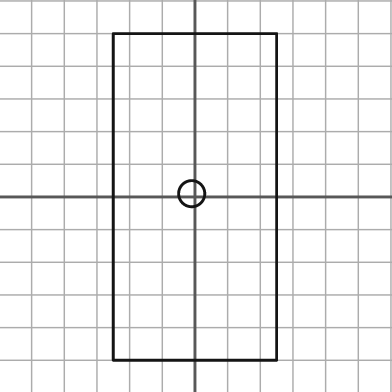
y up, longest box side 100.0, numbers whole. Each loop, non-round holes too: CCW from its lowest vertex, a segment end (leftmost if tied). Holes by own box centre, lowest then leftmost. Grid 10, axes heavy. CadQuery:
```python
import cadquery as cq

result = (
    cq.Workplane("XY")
    .moveTo(-25.0, -50.0)
    .lineTo(25.0, -50.0)
    .lineTo(25.0, 50.0)
    .lineTo(-25.0, 50.0)
    .close()
    .moveTo(-1.0, 1.0)
    .circle(4.0)
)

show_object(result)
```